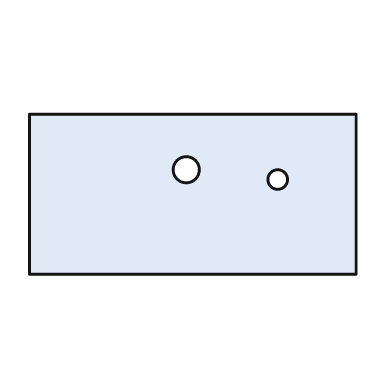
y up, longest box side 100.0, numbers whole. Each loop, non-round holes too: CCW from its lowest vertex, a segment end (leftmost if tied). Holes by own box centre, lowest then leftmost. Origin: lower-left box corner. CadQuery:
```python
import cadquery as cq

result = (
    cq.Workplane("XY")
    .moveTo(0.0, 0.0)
    .lineTo(100.0, 0.0)
    .lineTo(100.0, 49.0)
    .lineTo(0.0, 49.0)
    .close()
    .moveTo(76.0, 29.0)
    .circle(3.0)
    .moveTo(48.0, 32.0)
    .circle(4.0)
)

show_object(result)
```